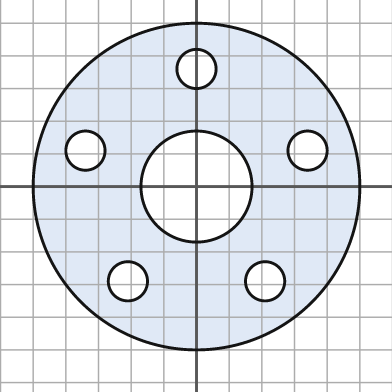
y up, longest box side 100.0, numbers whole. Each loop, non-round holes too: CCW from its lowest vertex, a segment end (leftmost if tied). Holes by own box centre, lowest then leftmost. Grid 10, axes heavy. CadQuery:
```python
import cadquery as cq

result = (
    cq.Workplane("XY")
    .moveTo(0.0, 0.0)
    .circle(50.0)
    .moveTo(-21.0, -29.0)
    .circle(6.0)
    .moveTo(21.0, -29.0)
    .circle(6.0)
    .moveTo(0.0, 0.0)
    .circle(17.0)
    .moveTo(-34.0, 11.0)
    .circle(6.0)
    .moveTo(34.0, 11.0)
    .circle(6.0)
    .moveTo(0.0, 36.0)
    .circle(6.0)
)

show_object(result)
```